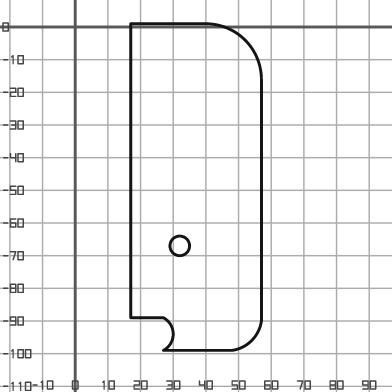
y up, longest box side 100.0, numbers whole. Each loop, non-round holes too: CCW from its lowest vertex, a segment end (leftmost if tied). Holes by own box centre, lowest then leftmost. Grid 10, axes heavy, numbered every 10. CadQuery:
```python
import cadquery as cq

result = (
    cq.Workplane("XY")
    .moveTo(27.0, -99.0)
    .lineTo(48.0, -99.0)
    .threePointArc((54.0, -96.0), (57.0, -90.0))
    .lineTo(57.0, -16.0)
    .threePointArc((52.0, -4.0), (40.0, 1.0))
    .lineTo(17.0, 1.0)
    .lineTo(17.0, -89.0)
    .lineTo(27.0, -89.0)
    .threePointArc((30.0, -94.0), (27.0, -99.0))
    .close()
    .moveTo(32.0, -67.0)
    .circle(3.0)
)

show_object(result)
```